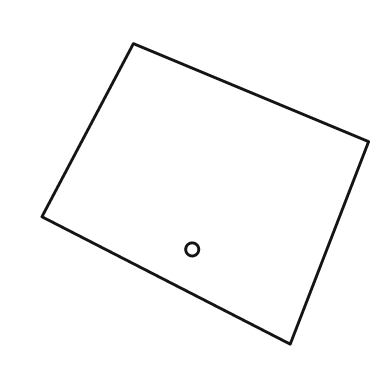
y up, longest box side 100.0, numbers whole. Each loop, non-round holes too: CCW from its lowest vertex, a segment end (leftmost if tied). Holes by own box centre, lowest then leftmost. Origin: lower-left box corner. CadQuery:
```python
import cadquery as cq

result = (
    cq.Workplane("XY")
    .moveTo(76.0, 0.0)
    .lineTo(100.0, 62.0)
    .lineTo(28.0, 92.0)
    .lineTo(0.0, 39.0)
    .close()
    .moveTo(46.0, 29.0)
    .circle(2.0)
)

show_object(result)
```